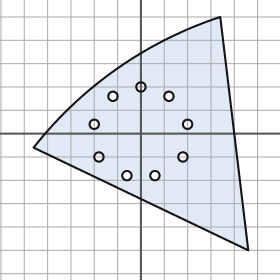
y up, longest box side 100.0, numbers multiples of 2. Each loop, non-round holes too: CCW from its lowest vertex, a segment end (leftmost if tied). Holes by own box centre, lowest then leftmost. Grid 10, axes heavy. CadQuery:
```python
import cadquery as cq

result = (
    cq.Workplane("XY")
    .moveTo(46.0, -50.0)
    .lineTo(34.0, 50.0)
    .threePointArc((-10.0, 28.0), (-46.0, -6.0))
    .close()
    .moveTo(-6.0, -18.0)
    .circle(2.0)
    .moveTo(6.0, -18.0)
    .circle(2.0)
    .moveTo(-18.0, -10.0)
    .circle(2.0)
    .moveTo(18.0, -10.0)
    .circle(2.0)
    .moveTo(-20.0, 4.0)
    .circle(2.0)
    .moveTo(20.0, 4.0)
    .circle(2.0)
    .moveTo(-12.0, 16.0)
    .circle(2.0)
    .moveTo(12.0, 16.0)
    .circle(2.0)
    .moveTo(0.0, 20.0)
    .circle(2.0)
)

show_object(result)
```